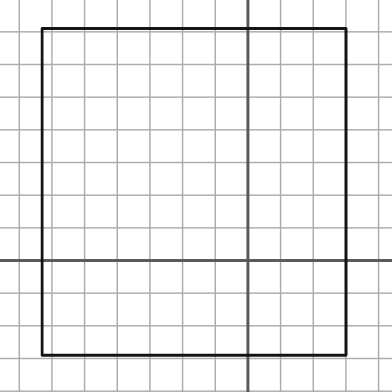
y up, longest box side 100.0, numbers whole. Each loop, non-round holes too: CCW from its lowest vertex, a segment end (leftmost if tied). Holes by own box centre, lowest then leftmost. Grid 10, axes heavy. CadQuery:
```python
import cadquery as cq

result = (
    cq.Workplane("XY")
    .moveTo(-63.0, -29.0)
    .lineTo(30.0, -29.0)
    .lineTo(30.0, 71.0)
    .lineTo(-63.0, 71.0)
    .close()
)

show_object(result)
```